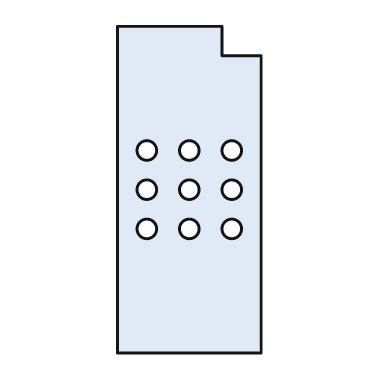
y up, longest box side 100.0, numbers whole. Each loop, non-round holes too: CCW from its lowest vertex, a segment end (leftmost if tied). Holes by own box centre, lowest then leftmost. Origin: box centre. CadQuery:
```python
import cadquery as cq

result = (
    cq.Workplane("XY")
    .moveTo(-22.0, -50.0)
    .lineTo(22.0, -50.0)
    .lineTo(22.0, 41.0)
    .lineTo(10.0, 41.0)
    .lineTo(10.0, 50.0)
    .lineTo(-22.0, 50.0)
    .close()
    .moveTo(-13.0, -12.0)
    .circle(3.0)
    .moveTo(0.0, -12.0)
    .circle(3.0)
    .moveTo(13.0, -12.0)
    .circle(3.0)
    .moveTo(-13.0, 0.0)
    .circle(3.0)
    .moveTo(0.0, 0.0)
    .circle(3.0)
    .moveTo(13.0, 0.0)
    .circle(3.0)
    .moveTo(-13.0, 12.0)
    .circle(3.0)
    .moveTo(0.0, 12.0)
    .circle(3.0)
    .moveTo(13.0, 12.0)
    .circle(3.0)
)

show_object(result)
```